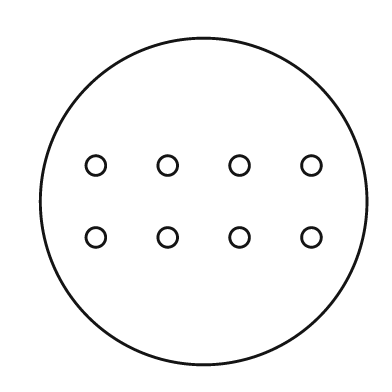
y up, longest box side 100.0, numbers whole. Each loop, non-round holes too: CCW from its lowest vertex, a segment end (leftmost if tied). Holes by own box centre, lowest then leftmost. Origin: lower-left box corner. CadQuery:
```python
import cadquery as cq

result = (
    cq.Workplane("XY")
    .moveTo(50.0, 50.0)
    .circle(50.0)
    .moveTo(17.0, 39.0)
    .circle(3.0)
    .moveTo(39.0, 39.0)
    .circle(3.0)
    .moveTo(61.0, 39.0)
    .circle(3.0)
    .moveTo(83.0, 39.0)
    .circle(3.0)
    .moveTo(17.0, 61.0)
    .circle(3.0)
    .moveTo(39.0, 61.0)
    .circle(3.0)
    .moveTo(61.0, 61.0)
    .circle(3.0)
    .moveTo(83.0, 61.0)
    .circle(3.0)
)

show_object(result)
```